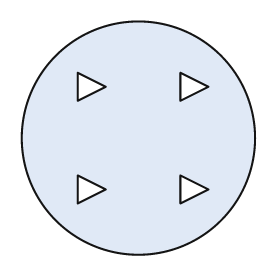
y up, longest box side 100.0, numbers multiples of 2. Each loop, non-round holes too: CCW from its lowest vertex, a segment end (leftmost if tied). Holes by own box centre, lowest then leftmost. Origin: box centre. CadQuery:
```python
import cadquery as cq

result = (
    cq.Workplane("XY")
    .moveTo(0.0, 0.0)
    .circle(50.0)
    .moveTo(-26.0, -28.0)
    .lineTo(-14.0, -22.0)
    .lineTo(-26.0, -16.0)
    .close()
    .moveTo(18.0, -28.0)
    .lineTo(30.0, -22.0)
    .lineTo(18.0, -16.0)
    .close()
    .moveTo(-26.0, 16.0)
    .lineTo(-14.0, 22.0)
    .lineTo(-26.0, 28.0)
    .close()
    .moveTo(18.0, 16.0)
    .lineTo(30.0, 22.0)
    .lineTo(18.0, 28.0)
    .close()
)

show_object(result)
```